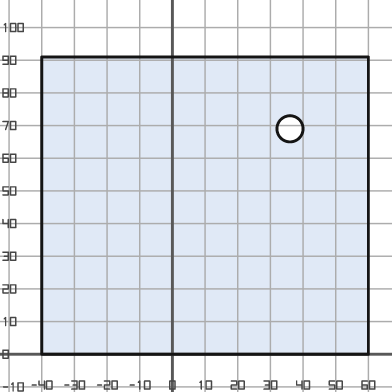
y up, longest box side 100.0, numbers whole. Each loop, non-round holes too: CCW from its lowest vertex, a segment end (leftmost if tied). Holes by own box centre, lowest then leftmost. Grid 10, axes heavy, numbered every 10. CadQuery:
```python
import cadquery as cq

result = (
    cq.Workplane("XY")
    .moveTo(-40.0, 0.0)
    .lineTo(60.0, 0.0)
    .lineTo(60.0, 91.0)
    .lineTo(-40.0, 91.0)
    .close()
    .moveTo(36.0, 69.0)
    .circle(4.0)
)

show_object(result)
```